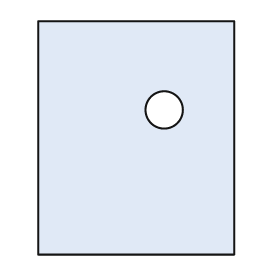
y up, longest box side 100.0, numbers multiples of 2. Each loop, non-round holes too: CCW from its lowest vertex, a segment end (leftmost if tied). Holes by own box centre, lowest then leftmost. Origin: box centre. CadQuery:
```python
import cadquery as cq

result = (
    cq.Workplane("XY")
    .moveTo(-42.0, -50.0)
    .lineTo(42.0, -50.0)
    .lineTo(42.0, 50.0)
    .lineTo(-42.0, 50.0)
    .close()
    .moveTo(12.0, 12.0)
    .circle(8.0)
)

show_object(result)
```